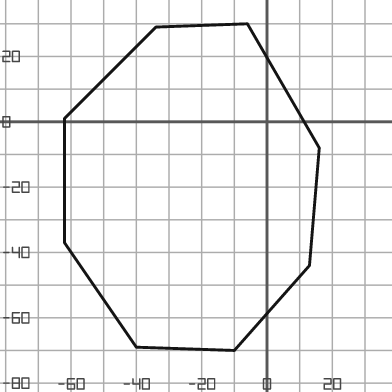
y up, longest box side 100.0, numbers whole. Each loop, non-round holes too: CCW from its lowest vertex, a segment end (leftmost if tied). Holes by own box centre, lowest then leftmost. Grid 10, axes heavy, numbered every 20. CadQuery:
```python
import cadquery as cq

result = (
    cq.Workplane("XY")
    .moveTo(-10.0, -70.0)
    .lineTo(13.0, -44.0)
    .lineTo(16.0, -8.0)
    .lineTo(-6.0, 30.0)
    .lineTo(-34.0, 29.0)
    .lineTo(-62.0, 1.0)
    .lineTo(-62.0, -37.0)
    .lineTo(-40.0, -69.0)
    .close()
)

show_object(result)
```